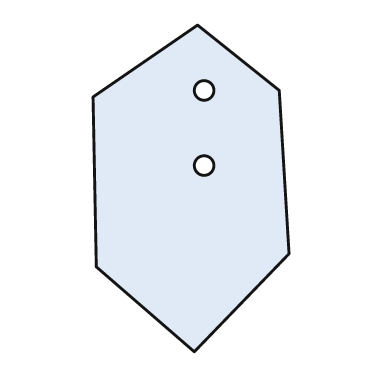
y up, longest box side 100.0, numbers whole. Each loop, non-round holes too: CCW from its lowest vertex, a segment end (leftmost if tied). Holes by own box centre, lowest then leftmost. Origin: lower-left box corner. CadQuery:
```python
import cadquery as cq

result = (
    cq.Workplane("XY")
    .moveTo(31.0, 0.0)
    .lineTo(60.0, 30.0)
    .lineTo(57.0, 80.0)
    .lineTo(32.0, 100.0)
    .lineTo(0.0, 78.0)
    .lineTo(1.0, 26.0)
    .close()
    .moveTo(34.0, 57.0)
    .circle(3.0)
    .moveTo(34.0, 80.0)
    .circle(3.0)
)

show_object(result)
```